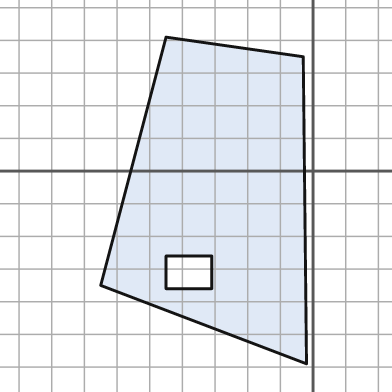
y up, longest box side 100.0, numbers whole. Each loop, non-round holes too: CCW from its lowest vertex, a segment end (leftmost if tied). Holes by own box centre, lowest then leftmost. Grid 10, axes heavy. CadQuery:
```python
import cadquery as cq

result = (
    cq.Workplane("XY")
    .moveTo(-2.0, -59.0)
    .lineTo(-3.0, 35.0)
    .lineTo(-45.0, 41.0)
    .lineTo(-65.0, -35.0)
    .close()
    .moveTo(-45.0, -36.0)
    .lineTo(-31.0, -36.0)
    .lineTo(-31.0, -26.0)
    .lineTo(-45.0, -26.0)
    .close()
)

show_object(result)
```